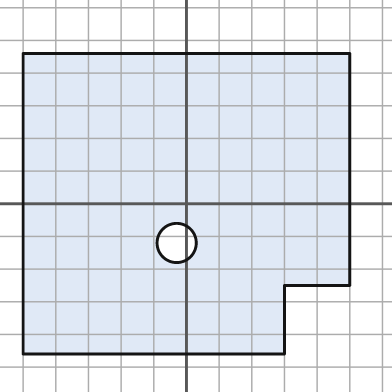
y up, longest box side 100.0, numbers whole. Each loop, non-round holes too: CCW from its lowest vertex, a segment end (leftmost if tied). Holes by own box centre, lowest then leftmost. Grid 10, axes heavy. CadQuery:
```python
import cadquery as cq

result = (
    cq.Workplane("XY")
    .moveTo(-50.0, -46.0)
    .lineTo(30.0, -46.0)
    .lineTo(30.0, -25.0)
    .lineTo(50.0, -25.0)
    .lineTo(50.0, 46.0)
    .lineTo(-50.0, 46.0)
    .close()
    .moveTo(-3.0, -12.0)
    .circle(6.0)
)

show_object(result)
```